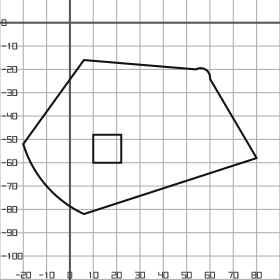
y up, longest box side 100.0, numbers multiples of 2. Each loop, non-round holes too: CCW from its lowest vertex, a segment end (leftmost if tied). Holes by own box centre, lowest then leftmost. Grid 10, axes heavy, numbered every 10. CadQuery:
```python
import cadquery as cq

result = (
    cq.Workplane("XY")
    .moveTo(6.0, -82.0)
    .lineTo(80.0, -58.0)
    .lineTo(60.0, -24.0)
    .threePointArc((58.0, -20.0), (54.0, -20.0))
    .lineTo(6.0, -16.0)
    .lineTo(-20.0, -52.0)
    .threePointArc((-10.0, -70.0), (6.0, -82.0))
    .close()
    .moveTo(10.0, -60.0)
    .lineTo(22.0, -60.0)
    .lineTo(22.0, -48.0)
    .lineTo(10.0, -48.0)
    .close()
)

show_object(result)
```